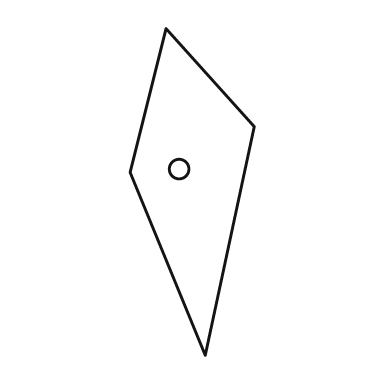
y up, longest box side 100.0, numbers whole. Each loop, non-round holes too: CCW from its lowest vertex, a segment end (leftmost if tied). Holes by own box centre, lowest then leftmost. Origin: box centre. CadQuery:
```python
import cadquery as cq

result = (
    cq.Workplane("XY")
    .moveTo(4.0, -50.0)
    .lineTo(19.0, 20.0)
    .lineTo(-8.0, 50.0)
    .lineTo(-19.0, 6.0)
    .close()
    .moveTo(-4.0, 7.0)
    .circle(3.0)
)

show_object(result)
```